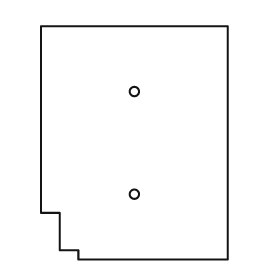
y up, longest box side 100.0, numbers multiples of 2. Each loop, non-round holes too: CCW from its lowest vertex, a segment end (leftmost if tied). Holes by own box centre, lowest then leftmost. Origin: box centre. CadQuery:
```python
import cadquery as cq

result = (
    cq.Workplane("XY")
    .moveTo(-24.0, -50.0)
    .lineTo(40.0, -50.0)
    .lineTo(40.0, 50.0)
    .lineTo(-40.0, 50.0)
    .lineTo(-40.0, -30.0)
    .lineTo(-32.0, -30.0)
    .lineTo(-32.0, -46.0)
    .lineTo(-24.0, -46.0)
    .close()
    .moveTo(0.0, -22.0)
    .circle(2.0)
    .moveTo(0.0, 22.0)
    .circle(2.0)
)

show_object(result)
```